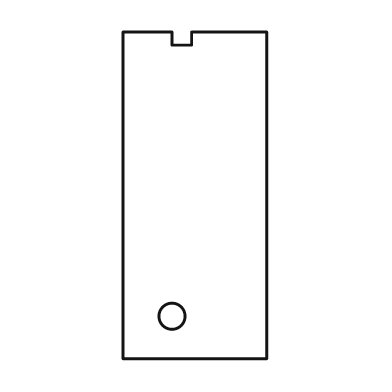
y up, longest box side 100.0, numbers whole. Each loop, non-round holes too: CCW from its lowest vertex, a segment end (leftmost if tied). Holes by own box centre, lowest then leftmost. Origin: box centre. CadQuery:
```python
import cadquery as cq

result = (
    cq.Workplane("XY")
    .moveTo(-22.0, -50.0)
    .lineTo(22.0, -50.0)
    .lineTo(22.0, 50.0)
    .lineTo(-1.0, 50.0)
    .lineTo(-1.0, 46.0)
    .lineTo(-7.0, 46.0)
    .lineTo(-7.0, 50.0)
    .lineTo(-22.0, 50.0)
    .close()
    .moveTo(-7.0, -37.0)
    .circle(4.0)
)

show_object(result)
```